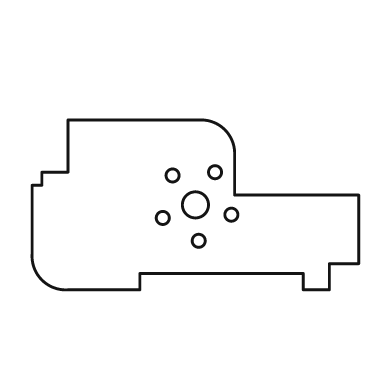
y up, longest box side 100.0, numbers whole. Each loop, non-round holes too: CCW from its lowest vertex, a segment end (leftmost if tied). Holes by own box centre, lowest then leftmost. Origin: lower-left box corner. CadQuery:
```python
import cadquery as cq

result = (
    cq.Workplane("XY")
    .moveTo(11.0, 0.0)
    .lineTo(33.0, 0.0)
    .lineTo(33.0, 5.0)
    .lineTo(83.0, 5.0)
    .lineTo(83.0, 0.0)
    .lineTo(91.0, 0.0)
    .lineTo(91.0, 8.0)
    .lineTo(100.0, 8.0)
    .lineTo(100.0, 29.0)
    .lineTo(62.0, 29.0)
    .lineTo(62.0, 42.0)
    .threePointArc((59.0, 49.0), (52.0, 52.0))
    .lineTo(11.0, 52.0)
    .lineTo(11.0, 36.0)
    .lineTo(3.0, 36.0)
    .lineTo(3.0, 32.0)
    .lineTo(0.0, 32.0)
    .lineTo(0.0, 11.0)
    .threePointArc((3.0, 3.0), (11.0, 0.0))
    .close()
    .moveTo(51.0, 15.0)
    .circle(2.0)
    .moveTo(40.0, 22.0)
    .circle(2.0)
    .moveTo(61.0, 23.0)
    .circle(2.0)
    .moveTo(50.0, 26.0)
    .circle(4.0)
    .moveTo(43.0, 35.0)
    .circle(2.0)
    .moveTo(56.0, 36.0)
    .circle(2.0)
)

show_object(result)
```